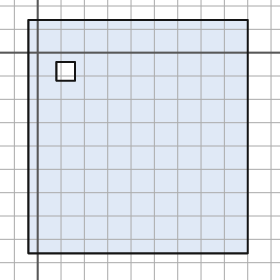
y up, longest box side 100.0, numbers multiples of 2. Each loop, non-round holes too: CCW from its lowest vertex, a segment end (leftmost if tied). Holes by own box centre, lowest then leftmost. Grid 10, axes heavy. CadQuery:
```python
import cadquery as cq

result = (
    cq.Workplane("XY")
    .moveTo(-4.0, -86.0)
    .lineTo(90.0, -86.0)
    .lineTo(90.0, 14.0)
    .lineTo(-4.0, 14.0)
    .close()
    .moveTo(8.0, -12.0)
    .lineTo(16.0, -12.0)
    .lineTo(16.0, -4.0)
    .lineTo(8.0, -4.0)
    .close()
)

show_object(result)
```